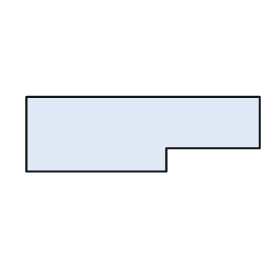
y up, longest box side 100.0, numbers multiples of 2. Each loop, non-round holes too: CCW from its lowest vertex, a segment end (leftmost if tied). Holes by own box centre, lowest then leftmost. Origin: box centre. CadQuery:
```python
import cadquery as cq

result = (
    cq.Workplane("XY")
    .moveTo(-50.0, -16.0)
    .lineTo(10.0, -16.0)
    .lineTo(10.0, -6.0)
    .lineTo(50.0, -6.0)
    .lineTo(50.0, 16.0)
    .lineTo(-50.0, 16.0)
    .close()
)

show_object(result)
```